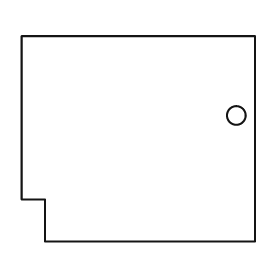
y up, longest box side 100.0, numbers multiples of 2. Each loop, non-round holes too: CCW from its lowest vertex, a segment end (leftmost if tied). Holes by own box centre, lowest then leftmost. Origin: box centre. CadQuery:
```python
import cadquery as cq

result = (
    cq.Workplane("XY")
    .moveTo(-40.0, -44.0)
    .lineTo(50.0, -44.0)
    .lineTo(50.0, 44.0)
    .lineTo(-50.0, 44.0)
    .lineTo(-50.0, -26.0)
    .lineTo(-40.0, -26.0)
    .close()
    .moveTo(42.0, 10.0)
    .circle(4.0)
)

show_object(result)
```